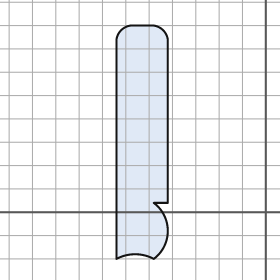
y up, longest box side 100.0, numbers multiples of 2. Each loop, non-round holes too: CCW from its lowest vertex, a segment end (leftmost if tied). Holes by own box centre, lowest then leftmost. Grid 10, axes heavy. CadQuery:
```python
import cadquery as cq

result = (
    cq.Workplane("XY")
    .moveTo(-64.0, -20.0)
    .threePointArc((-56.0, -18.0), (-48.0, -20.0))
    .threePointArc((-42.0, -8.0), (-48.0, 4.0))
    .lineTo(-42.0, 4.0)
    .lineTo(-42.0, 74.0)
    .threePointArc((-44.0, 78.0), (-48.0, 80.0))
    .lineTo(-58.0, 80.0)
    .threePointArc((-62.0, 78.0), (-64.0, 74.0))
    .close()
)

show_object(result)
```